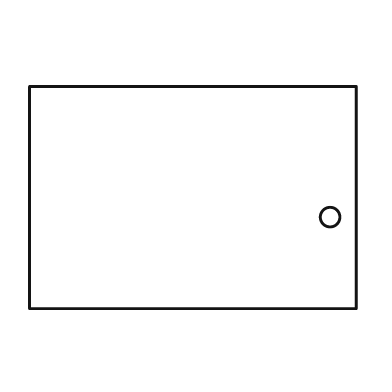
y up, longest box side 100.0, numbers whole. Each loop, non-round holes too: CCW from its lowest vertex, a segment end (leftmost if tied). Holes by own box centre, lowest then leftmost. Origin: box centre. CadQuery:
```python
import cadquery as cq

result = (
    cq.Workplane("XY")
    .moveTo(-50.0, -34.0)
    .lineTo(50.0, -34.0)
    .lineTo(50.0, 34.0)
    .lineTo(-50.0, 34.0)
    .close()
    .moveTo(42.0, -6.0)
    .circle(3.0)
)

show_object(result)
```